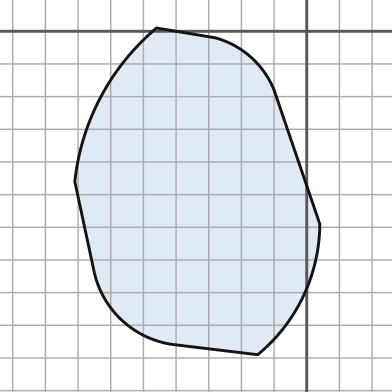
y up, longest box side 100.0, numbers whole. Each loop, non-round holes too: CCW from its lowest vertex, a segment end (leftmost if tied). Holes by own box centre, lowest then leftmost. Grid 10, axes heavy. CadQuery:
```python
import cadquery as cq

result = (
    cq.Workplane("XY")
    .moveTo(-15.0, -99.0)
    .threePointArc((-1.0, -81.0), (4.0, -59.0))
    .lineTo(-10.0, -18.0)
    .threePointArc((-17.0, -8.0), (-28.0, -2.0))
    .lineTo(-46.0, 1.0)
    .threePointArc((-63.0, -20.0), (-71.0, -46.0))
    .lineTo(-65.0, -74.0)
    .threePointArc((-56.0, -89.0), (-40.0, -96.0))
    .close()
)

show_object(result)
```